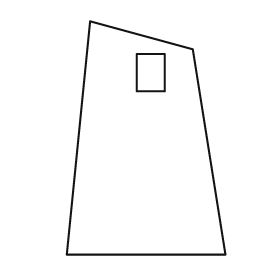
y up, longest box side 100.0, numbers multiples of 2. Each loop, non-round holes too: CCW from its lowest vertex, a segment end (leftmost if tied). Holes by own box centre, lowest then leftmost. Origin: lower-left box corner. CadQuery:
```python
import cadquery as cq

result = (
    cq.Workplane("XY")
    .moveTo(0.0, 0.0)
    .lineTo(68.0, 0.0)
    .lineTo(54.0, 88.0)
    .lineTo(10.0, 100.0)
    .close()
    .moveTo(30.0, 70.0)
    .lineTo(42.0, 70.0)
    .lineTo(42.0, 86.0)
    .lineTo(30.0, 86.0)
    .close()
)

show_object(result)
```